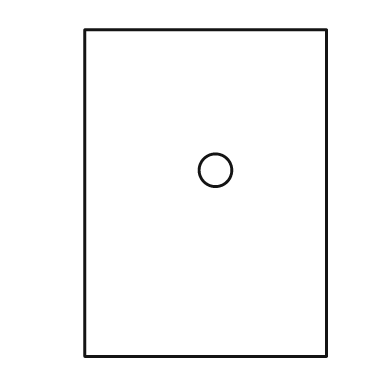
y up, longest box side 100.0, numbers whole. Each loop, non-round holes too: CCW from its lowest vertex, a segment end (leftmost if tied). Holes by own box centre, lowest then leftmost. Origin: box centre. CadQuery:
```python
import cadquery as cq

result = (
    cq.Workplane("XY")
    .moveTo(-37.0, -50.0)
    .lineTo(37.0, -50.0)
    .lineTo(37.0, 50.0)
    .lineTo(-37.0, 50.0)
    .close()
    .moveTo(3.0, 7.0)
    .circle(5.0)
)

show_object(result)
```